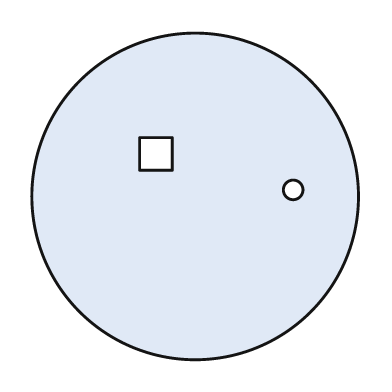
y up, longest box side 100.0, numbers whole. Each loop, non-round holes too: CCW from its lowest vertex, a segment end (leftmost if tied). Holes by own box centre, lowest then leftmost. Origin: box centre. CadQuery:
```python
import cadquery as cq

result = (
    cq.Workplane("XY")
    .moveTo(0.0, 0.0)
    .circle(50.0)
    .moveTo(30.0, 2.0)
    .circle(3.0)
    .moveTo(-17.0, 8.0)
    .lineTo(-7.0, 8.0)
    .lineTo(-7.0, 18.0)
    .lineTo(-17.0, 18.0)
    .close()
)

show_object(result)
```